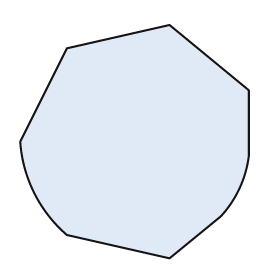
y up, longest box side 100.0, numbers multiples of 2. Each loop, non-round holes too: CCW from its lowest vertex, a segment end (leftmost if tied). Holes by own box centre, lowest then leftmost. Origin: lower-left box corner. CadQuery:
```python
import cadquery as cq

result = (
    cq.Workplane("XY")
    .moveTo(64.0, 0.0)
    .lineTo(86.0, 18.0)
    .threePointArc((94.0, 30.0), (98.0, 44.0))
    .lineTo(98.0, 72.0)
    .lineTo(64.0, 100.0)
    .lineTo(20.0, 90.0)
    .lineTo(0.0, 50.0)
    .threePointArc((6.0, 28.0), (20.0, 10.0))
    .close()
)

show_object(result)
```